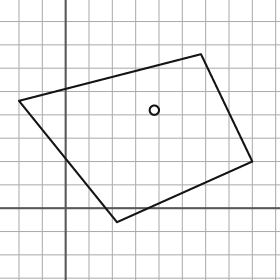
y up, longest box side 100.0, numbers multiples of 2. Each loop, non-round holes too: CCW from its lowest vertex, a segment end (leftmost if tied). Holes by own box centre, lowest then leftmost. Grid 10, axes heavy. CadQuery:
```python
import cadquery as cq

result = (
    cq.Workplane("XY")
    .moveTo(22.0, -6.0)
    .lineTo(80.0, 20.0)
    .lineTo(58.0, 66.0)
    .lineTo(-20.0, 46.0)
    .close()
    .moveTo(38.0, 42.0)
    .circle(2.0)
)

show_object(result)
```